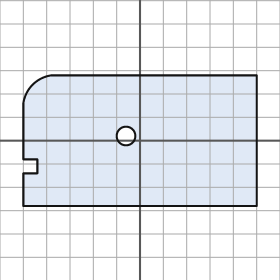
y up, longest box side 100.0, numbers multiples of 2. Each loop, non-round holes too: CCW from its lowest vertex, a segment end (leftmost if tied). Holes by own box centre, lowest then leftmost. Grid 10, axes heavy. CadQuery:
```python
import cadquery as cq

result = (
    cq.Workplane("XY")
    .moveTo(-50.0, -28.0)
    .lineTo(50.0, -28.0)
    .lineTo(50.0, 28.0)
    .lineTo(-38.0, 28.0)
    .threePointArc((-46.0, 24.0), (-50.0, 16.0))
    .lineTo(-50.0, -8.0)
    .lineTo(-44.0, -8.0)
    .lineTo(-44.0, -14.0)
    .lineTo(-50.0, -14.0)
    .close()
    .moveTo(-6.0, 2.0)
    .circle(4.0)
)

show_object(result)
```